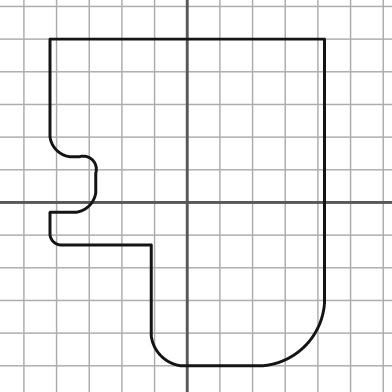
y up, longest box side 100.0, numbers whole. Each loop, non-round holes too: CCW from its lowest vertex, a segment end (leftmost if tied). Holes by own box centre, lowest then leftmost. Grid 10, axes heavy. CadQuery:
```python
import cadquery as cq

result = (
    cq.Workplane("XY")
    .moveTo(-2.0, -50.0)
    .lineTo(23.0, -50.0)
    .threePointArc((36.0, -44.0), (42.0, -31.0))
    .lineTo(42.0, 50.0)
    .lineTo(-42.0, 50.0)
    .lineTo(-42.0, 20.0)
    .threePointArc((-40.0, 16.0), (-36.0, 14.0))
    .lineTo(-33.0, 14.0)
    .threePointArc((-29.0, 13.0), (-28.0, 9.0))
    .lineTo(-28.0, 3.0)
    .threePointArc((-30.0, -1.0), (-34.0, -3.0))
    .lineTo(-42.0, -3.0)
    .lineTo(-42.0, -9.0)
    .threePointArc((-41.0, -12.0), (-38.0, -13.0))
    .lineTo(-11.0, -13.0)
    .lineTo(-11.0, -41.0)
    .threePointArc((-8.0, -47.0), (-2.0, -50.0))
    .close()
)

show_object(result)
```